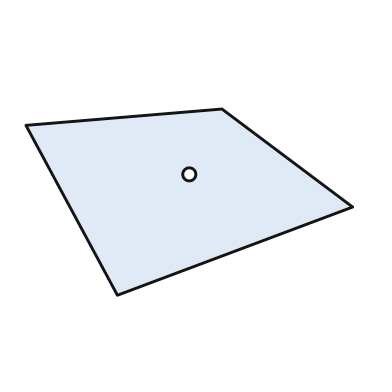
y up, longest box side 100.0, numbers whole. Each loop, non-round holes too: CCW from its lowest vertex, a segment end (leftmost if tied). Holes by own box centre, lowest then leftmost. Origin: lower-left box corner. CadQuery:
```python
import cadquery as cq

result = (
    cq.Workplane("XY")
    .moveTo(28.0, 0.0)
    .lineTo(100.0, 27.0)
    .lineTo(60.0, 57.0)
    .lineTo(0.0, 52.0)
    .close()
    .moveTo(50.0, 37.0)
    .circle(2.0)
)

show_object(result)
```